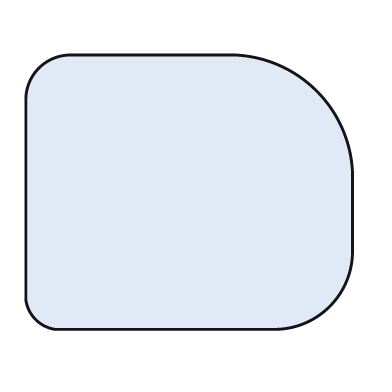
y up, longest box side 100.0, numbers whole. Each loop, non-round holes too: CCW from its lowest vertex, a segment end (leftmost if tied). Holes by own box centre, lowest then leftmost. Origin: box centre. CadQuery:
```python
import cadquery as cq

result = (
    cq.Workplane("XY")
    .moveTo(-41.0, -42.0)
    .lineTo(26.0, -42.0)
    .threePointArc((43.0, -35.0), (50.0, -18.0))
    .lineTo(50.0, 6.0)
    .threePointArc((39.0, 31.0), (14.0, 42.0))
    .lineTo(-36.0, 42.0)
    .threePointArc((-46.0, 38.0), (-50.0, 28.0))
    .lineTo(-50.0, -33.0)
    .threePointArc((-47.0, -39.0), (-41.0, -42.0))
    .close()
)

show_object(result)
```